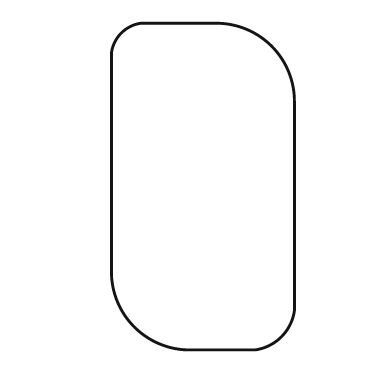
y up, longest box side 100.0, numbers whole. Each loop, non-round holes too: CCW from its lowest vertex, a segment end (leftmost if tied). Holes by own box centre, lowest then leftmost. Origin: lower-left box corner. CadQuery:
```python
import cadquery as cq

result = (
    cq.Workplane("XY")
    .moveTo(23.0, 0.0)
    .lineTo(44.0, 0.0)
    .threePointArc((52.0, 4.0), (56.0, 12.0))
    .lineTo(56.0, 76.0)
    .threePointArc((49.0, 93.0), (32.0, 100.0))
    .lineTo(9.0, 100.0)
    .threePointArc((3.0, 97.0), (0.0, 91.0))
    .lineTo(0.0, 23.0)
    .threePointArc((7.0, 7.0), (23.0, 0.0))
    .close()
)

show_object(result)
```